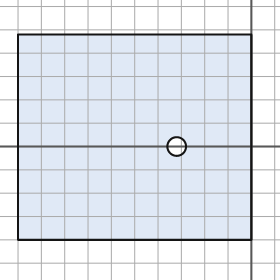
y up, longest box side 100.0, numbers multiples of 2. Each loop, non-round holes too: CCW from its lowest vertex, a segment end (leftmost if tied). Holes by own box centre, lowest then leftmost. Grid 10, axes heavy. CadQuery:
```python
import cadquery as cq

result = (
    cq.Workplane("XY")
    .moveTo(-100.0, -40.0)
    .lineTo(0.0, -40.0)
    .lineTo(0.0, 48.0)
    .lineTo(-100.0, 48.0)
    .close()
    .moveTo(-32.0, 0.0)
    .circle(4.0)
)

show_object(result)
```